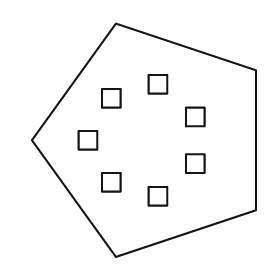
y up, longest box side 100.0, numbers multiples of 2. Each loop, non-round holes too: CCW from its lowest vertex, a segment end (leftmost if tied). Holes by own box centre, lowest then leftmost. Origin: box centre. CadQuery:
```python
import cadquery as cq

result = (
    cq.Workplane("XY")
    .moveTo(-12.0, -50.0)
    .lineTo(48.0, -30.0)
    .lineTo(48.0, 30.0)
    .lineTo(-12.0, 50.0)
    .lineTo(-48.0, 0.0)
    .close()
    .moveTo(2.0, -28.0)
    .lineTo(10.0, -28.0)
    .lineTo(10.0, -20.0)
    .lineTo(2.0, -20.0)
    .close()
    .moveTo(-18.0, -22.0)
    .lineTo(-10.0, -22.0)
    .lineTo(-10.0, -14.0)
    .lineTo(-18.0, -14.0)
    .close()
    .moveTo(18.0, -14.0)
    .lineTo(26.0, -14.0)
    .lineTo(26.0, -6.0)
    .lineTo(18.0, -6.0)
    .close()
    .moveTo(-28.0, -4.0)
    .lineTo(-20.0, -4.0)
    .lineTo(-20.0, 4.0)
    .lineTo(-28.0, 4.0)
    .close()
    .moveTo(18.0, 6.0)
    .lineTo(26.0, 6.0)
    .lineTo(26.0, 14.0)
    .lineTo(18.0, 14.0)
    .close()
    .moveTo(-18.0, 14.0)
    .lineTo(-10.0, 14.0)
    .lineTo(-10.0, 22.0)
    .lineTo(-18.0, 22.0)
    .close()
    .moveTo(2.0, 20.0)
    .lineTo(10.0, 20.0)
    .lineTo(10.0, 28.0)
    .lineTo(2.0, 28.0)
    .close()
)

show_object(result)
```